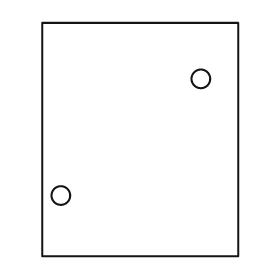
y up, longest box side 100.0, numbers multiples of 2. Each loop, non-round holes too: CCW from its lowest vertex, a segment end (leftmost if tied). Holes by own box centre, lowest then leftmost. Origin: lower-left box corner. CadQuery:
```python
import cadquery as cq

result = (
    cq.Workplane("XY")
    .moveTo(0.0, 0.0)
    .lineTo(84.0, 0.0)
    .lineTo(84.0, 100.0)
    .lineTo(0.0, 100.0)
    .close()
    .moveTo(8.0, 26.0)
    .circle(4.0)
    .moveTo(68.0, 76.0)
    .circle(4.0)
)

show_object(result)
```